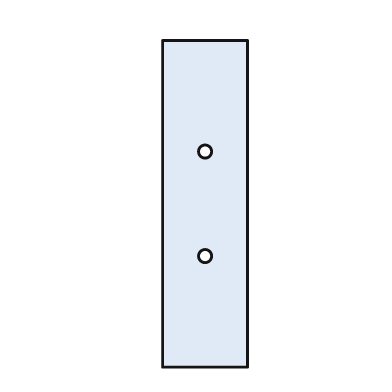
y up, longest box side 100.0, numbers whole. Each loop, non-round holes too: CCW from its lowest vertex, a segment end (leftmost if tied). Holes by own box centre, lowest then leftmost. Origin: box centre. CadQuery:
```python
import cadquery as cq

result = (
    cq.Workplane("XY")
    .moveTo(-13.0, -50.0)
    .lineTo(13.0, -50.0)
    .lineTo(13.0, 50.0)
    .lineTo(-13.0, 50.0)
    .close()
    .moveTo(0.0, -16.0)
    .circle(2.0)
    .moveTo(0.0, 16.0)
    .circle(2.0)
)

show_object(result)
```